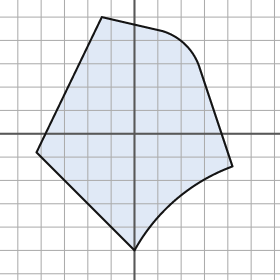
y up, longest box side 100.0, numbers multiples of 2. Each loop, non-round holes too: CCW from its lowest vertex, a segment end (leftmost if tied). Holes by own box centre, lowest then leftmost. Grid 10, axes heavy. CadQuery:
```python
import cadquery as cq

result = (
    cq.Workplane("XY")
    .moveTo(0.0, -50.0)
    .threePointArc((18.0, -28.0), (42.0, -14.0))
    .lineTo(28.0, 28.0)
    .threePointArc((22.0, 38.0), (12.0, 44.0))
    .lineTo(-14.0, 50.0)
    .lineTo(-42.0, -8.0)
    .close()
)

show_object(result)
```